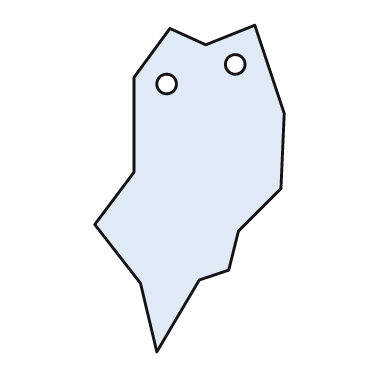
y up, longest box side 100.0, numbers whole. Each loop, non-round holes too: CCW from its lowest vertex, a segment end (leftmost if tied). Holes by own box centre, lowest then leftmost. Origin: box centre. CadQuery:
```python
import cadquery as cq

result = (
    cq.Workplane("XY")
    .moveTo(-10.0, -50.0)
    .lineTo(3.0, -28.0)
    .lineTo(12.0, -25.0)
    .lineTo(15.0, -13.0)
    .lineTo(28.0, 0.0)
    .lineTo(29.0, 23.0)
    .lineTo(20.0, 50.0)
    .lineTo(5.0, 44.0)
    .lineTo(-6.0, 49.0)
    .lineTo(-17.0, 34.0)
    .lineTo(-17.0, 5.0)
    .lineTo(-29.0, -11.0)
    .lineTo(-15.0, -29.0)
    .close()
    .moveTo(-7.0, 32.0)
    .circle(3.0)
    .moveTo(14.0, 38.0)
    .circle(3.0)
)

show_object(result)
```